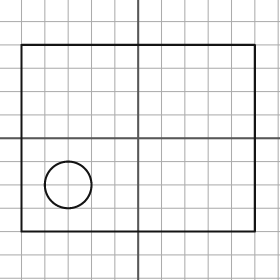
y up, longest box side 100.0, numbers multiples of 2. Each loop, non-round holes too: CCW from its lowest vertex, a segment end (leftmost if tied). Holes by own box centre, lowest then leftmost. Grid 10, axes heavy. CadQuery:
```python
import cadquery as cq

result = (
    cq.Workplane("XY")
    .moveTo(-50.0, -40.0)
    .lineTo(50.0, -40.0)
    .lineTo(50.0, 40.0)
    .lineTo(-50.0, 40.0)
    .close()
    .moveTo(-30.0, -20.0)
    .circle(10.0)
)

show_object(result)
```